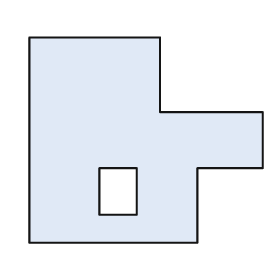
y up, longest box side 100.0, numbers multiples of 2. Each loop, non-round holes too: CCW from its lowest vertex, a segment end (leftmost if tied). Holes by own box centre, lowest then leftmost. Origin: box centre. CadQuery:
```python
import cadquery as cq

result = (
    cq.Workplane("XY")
    .moveTo(-50.0, -44.0)
    .lineTo(22.0, -44.0)
    .lineTo(22.0, -12.0)
    .lineTo(50.0, -12.0)
    .lineTo(50.0, 12.0)
    .lineTo(6.0, 12.0)
    .lineTo(6.0, 44.0)
    .lineTo(-50.0, 44.0)
    .close()
    .moveTo(-20.0, -32.0)
    .lineTo(-4.0, -32.0)
    .lineTo(-4.0, -12.0)
    .lineTo(-20.0, -12.0)
    .close()
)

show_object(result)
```